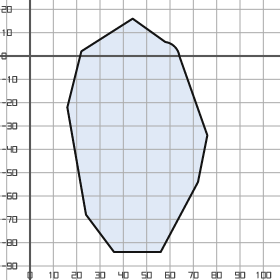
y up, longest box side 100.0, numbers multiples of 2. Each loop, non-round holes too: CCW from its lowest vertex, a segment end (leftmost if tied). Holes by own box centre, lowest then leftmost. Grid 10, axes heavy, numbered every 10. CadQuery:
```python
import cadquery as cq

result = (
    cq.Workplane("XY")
    .moveTo(36.0, -84.0)
    .lineTo(56.0, -84.0)
    .lineTo(72.0, -54.0)
    .lineTo(76.0, -34.0)
    .lineTo(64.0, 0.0)
    .threePointArc((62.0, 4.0), (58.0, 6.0))
    .lineTo(44.0, 16.0)
    .lineTo(22.0, 2.0)
    .lineTo(16.0, -22.0)
    .lineTo(24.0, -68.0)
    .close()
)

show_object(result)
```